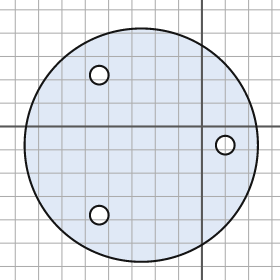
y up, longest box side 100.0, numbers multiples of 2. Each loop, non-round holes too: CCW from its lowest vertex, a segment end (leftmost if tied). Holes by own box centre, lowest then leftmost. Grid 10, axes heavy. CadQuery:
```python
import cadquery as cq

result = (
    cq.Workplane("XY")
    .moveTo(-26.0, -8.0)
    .circle(50.0)
    .moveTo(-44.0, -38.0)
    .circle(4.0)
    .moveTo(10.0, -8.0)
    .circle(4.0)
    .moveTo(-44.0, 22.0)
    .circle(4.0)
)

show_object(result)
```